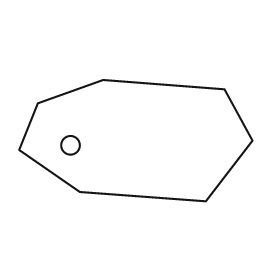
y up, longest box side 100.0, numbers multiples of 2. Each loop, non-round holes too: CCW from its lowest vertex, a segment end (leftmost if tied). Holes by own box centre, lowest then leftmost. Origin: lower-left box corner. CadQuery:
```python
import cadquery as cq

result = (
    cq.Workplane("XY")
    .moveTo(80.0, 0.0)
    .lineTo(100.0, 26.0)
    .lineTo(88.0, 48.0)
    .lineTo(36.0, 52.0)
    .lineTo(8.0, 42.0)
    .lineTo(0.0, 22.0)
    .lineTo(26.0, 4.0)
    .close()
    .moveTo(22.0, 24.0)
    .circle(4.0)
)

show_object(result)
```